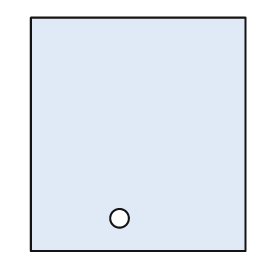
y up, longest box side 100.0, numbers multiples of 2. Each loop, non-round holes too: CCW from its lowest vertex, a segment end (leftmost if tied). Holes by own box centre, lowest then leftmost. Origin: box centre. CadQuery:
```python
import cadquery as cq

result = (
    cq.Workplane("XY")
    .moveTo(-46.0, -50.0)
    .lineTo(46.0, -50.0)
    .lineTo(46.0, 50.0)
    .lineTo(-46.0, 50.0)
    .close()
    .moveTo(-8.0, -36.0)
    .circle(4.0)
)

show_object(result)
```